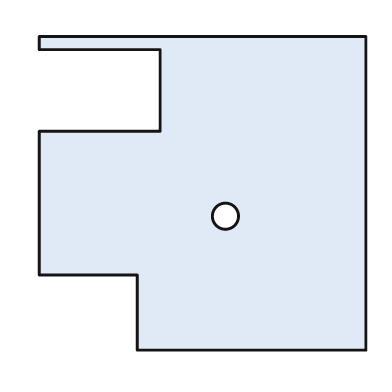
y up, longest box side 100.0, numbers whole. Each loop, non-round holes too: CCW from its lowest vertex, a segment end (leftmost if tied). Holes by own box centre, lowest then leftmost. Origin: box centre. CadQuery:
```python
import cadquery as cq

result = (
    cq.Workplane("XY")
    .moveTo(-20.0, -48.0)
    .lineTo(50.0, -48.0)
    .lineTo(50.0, 48.0)
    .lineTo(-50.0, 48.0)
    .lineTo(-50.0, 44.0)
    .lineTo(-13.0, 44.0)
    .lineTo(-13.0, 19.0)
    .lineTo(-50.0, 19.0)
    .lineTo(-50.0, -25.0)
    .lineTo(-20.0, -25.0)
    .close()
    .moveTo(7.0, -7.0)
    .circle(4.0)
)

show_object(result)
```